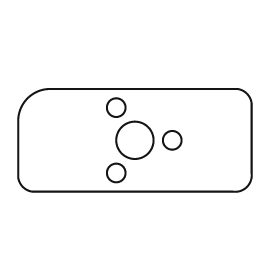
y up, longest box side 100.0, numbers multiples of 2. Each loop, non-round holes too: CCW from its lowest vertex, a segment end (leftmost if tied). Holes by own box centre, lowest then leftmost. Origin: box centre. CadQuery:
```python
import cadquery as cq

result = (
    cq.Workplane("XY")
    .moveTo(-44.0, -22.0)
    .lineTo(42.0, -22.0)
    .threePointArc((48.0, -20.0), (50.0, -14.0))
    .lineTo(50.0, 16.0)
    .threePointArc((48.0, 20.0), (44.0, 22.0))
    .lineTo(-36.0, 22.0)
    .threePointArc((-46.0, 18.0), (-50.0, 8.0))
    .lineTo(-50.0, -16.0)
    .threePointArc((-48.0, -20.0), (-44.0, -22.0))
    .close()
    .moveTo(-8.0, -14.0)
    .circle(4.0)
    .moveTo(0.0, 0.0)
    .circle(8.0)
    .moveTo(16.0, 0.0)
    .circle(4.0)
    .moveTo(-8.0, 14.0)
    .circle(4.0)
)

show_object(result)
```